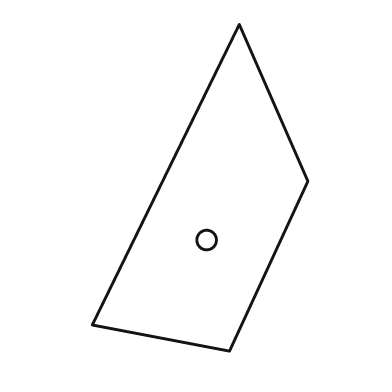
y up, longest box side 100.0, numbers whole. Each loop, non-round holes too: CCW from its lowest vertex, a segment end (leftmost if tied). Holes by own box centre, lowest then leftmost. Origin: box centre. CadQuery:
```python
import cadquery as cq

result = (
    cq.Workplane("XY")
    .moveTo(9.0, -50.0)
    .lineTo(33.0, 2.0)
    .lineTo(12.0, 50.0)
    .lineTo(-33.0, -42.0)
    .close()
    .moveTo(2.0, -16.0)
    .circle(3.0)
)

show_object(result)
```